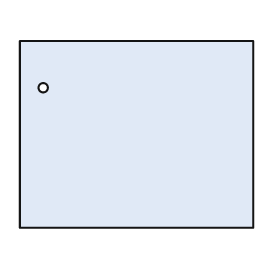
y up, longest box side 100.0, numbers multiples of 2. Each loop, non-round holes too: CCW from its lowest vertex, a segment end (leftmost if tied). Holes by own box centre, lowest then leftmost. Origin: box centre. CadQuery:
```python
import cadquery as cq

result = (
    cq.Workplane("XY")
    .moveTo(-50.0, -40.0)
    .lineTo(50.0, -40.0)
    .lineTo(50.0, 40.0)
    .lineTo(-50.0, 40.0)
    .close()
    .moveTo(-40.0, 20.0)
    .circle(2.0)
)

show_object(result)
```